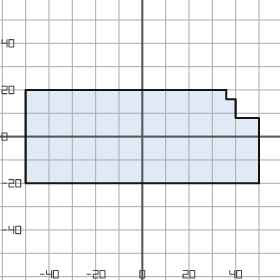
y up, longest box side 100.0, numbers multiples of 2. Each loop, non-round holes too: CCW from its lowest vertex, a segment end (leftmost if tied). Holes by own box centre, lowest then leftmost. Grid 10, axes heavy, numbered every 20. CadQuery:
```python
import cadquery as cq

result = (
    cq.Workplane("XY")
    .moveTo(-50.0, -20.0)
    .lineTo(50.0, -20.0)
    .lineTo(50.0, 8.0)
    .lineTo(40.0, 8.0)
    .lineTo(40.0, 16.0)
    .lineTo(36.0, 16.0)
    .lineTo(36.0, 20.0)
    .lineTo(-50.0, 20.0)
    .close()
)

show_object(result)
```